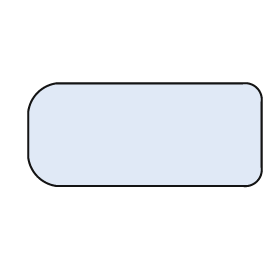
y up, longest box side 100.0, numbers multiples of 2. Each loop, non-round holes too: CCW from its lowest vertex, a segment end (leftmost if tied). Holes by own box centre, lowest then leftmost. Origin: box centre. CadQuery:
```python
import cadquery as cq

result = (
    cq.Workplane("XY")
    .moveTo(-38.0, -22.0)
    .lineTo(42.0, -22.0)
    .threePointArc((48.0, -20.0), (50.0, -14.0))
    .lineTo(50.0, 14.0)
    .threePointArc((48.0, 20.0), (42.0, 22.0))
    .lineTo(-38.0, 22.0)
    .threePointArc((-46.0, 18.0), (-50.0, 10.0))
    .lineTo(-50.0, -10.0)
    .threePointArc((-46.0, -18.0), (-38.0, -22.0))
    .close()
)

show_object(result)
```